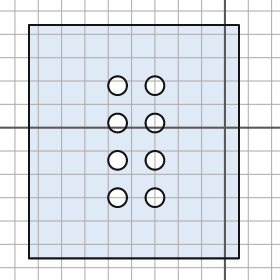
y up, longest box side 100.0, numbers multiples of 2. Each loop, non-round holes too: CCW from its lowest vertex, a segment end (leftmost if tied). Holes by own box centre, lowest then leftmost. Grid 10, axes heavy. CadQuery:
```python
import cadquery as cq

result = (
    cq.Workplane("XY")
    .moveTo(-84.0, -56.0)
    .lineTo(6.0, -56.0)
    .lineTo(6.0, 44.0)
    .lineTo(-84.0, 44.0)
    .close()
    .moveTo(-46.0, -30.0)
    .circle(4.0)
    .moveTo(-30.0, -30.0)
    .circle(4.0)
    .moveTo(-46.0, -14.0)
    .circle(4.0)
    .moveTo(-30.0, -14.0)
    .circle(4.0)
    .moveTo(-46.0, 2.0)
    .circle(4.0)
    .moveTo(-30.0, 2.0)
    .circle(4.0)
    .moveTo(-46.0, 18.0)
    .circle(4.0)
    .moveTo(-30.0, 18.0)
    .circle(4.0)
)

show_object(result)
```